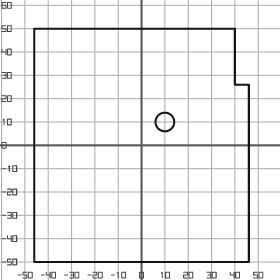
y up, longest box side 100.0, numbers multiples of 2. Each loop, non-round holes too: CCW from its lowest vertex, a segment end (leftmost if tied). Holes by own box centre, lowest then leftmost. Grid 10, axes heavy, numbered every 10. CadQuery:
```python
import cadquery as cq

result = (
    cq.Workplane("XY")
    .moveTo(-46.0, -50.0)
    .lineTo(46.0, -50.0)
    .lineTo(46.0, 26.0)
    .lineTo(40.0, 26.0)
    .lineTo(40.0, 50.0)
    .lineTo(-46.0, 50.0)
    .close()
    .moveTo(10.0, 10.0)
    .circle(4.0)
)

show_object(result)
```